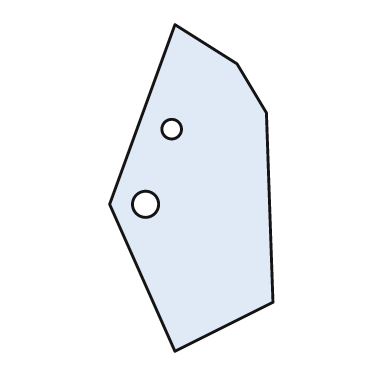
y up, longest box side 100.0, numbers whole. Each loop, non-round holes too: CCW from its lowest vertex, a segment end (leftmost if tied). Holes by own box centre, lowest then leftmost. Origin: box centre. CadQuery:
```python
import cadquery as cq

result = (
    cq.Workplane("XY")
    .moveTo(-5.0, -50.0)
    .lineTo(25.0, -35.0)
    .lineTo(23.0, 23.0)
    .lineTo(14.0, 38.0)
    .lineTo(-5.0, 50.0)
    .lineTo(-25.0, -5.0)
    .close()
    .moveTo(-14.0, -5.0)
    .circle(4.0)
    .moveTo(-6.0, 18.0)
    .circle(3.0)
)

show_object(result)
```